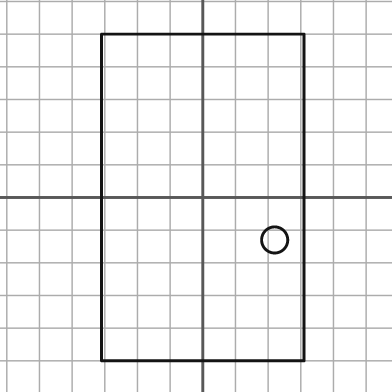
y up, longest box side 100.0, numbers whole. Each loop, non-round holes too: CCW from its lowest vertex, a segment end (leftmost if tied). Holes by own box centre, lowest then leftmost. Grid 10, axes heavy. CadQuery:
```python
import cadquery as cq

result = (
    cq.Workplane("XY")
    .moveTo(-31.0, -50.0)
    .lineTo(31.0, -50.0)
    .lineTo(31.0, 50.0)
    .lineTo(-31.0, 50.0)
    .close()
    .moveTo(22.0, -13.0)
    .circle(4.0)
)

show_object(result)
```